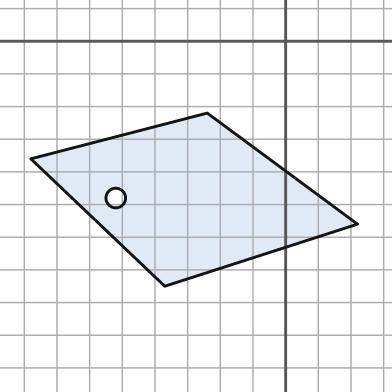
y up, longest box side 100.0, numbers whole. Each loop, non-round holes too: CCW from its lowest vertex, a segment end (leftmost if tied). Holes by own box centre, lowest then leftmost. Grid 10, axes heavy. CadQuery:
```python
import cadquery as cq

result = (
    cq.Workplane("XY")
    .moveTo(-37.0, -75.0)
    .lineTo(22.0, -56.0)
    .lineTo(-24.0, -22.0)
    .lineTo(-78.0, -36.0)
    .close()
    .moveTo(-52.0, -48.0)
    .circle(3.0)
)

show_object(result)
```